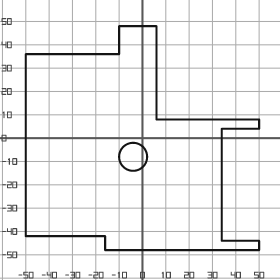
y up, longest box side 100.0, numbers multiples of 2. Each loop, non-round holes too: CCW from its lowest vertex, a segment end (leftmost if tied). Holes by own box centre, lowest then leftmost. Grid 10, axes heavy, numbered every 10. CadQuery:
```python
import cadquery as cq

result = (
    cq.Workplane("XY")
    .moveTo(-16.0, -48.0)
    .lineTo(50.0, -48.0)
    .lineTo(50.0, -44.0)
    .lineTo(34.0, -44.0)
    .lineTo(34.0, 4.0)
    .lineTo(50.0, 4.0)
    .lineTo(50.0, 8.0)
    .lineTo(6.0, 8.0)
    .lineTo(6.0, 48.0)
    .lineTo(-10.0, 48.0)
    .lineTo(-10.0, 36.0)
    .lineTo(-50.0, 36.0)
    .lineTo(-50.0, -42.0)
    .lineTo(-16.0, -42.0)
    .close()
    .moveTo(-4.0, -8.0)
    .circle(6.0)
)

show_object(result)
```